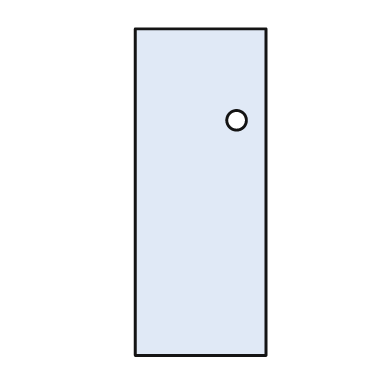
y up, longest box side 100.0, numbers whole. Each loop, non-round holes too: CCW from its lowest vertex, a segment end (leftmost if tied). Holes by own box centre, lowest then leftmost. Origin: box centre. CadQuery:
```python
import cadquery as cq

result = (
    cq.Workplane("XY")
    .moveTo(-20.0, -50.0)
    .lineTo(20.0, -50.0)
    .lineTo(20.0, 50.0)
    .lineTo(-20.0, 50.0)
    .close()
    .moveTo(11.0, 22.0)
    .circle(3.0)
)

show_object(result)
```